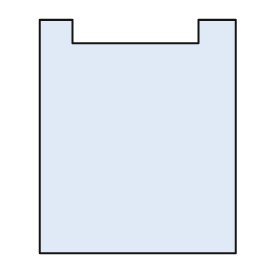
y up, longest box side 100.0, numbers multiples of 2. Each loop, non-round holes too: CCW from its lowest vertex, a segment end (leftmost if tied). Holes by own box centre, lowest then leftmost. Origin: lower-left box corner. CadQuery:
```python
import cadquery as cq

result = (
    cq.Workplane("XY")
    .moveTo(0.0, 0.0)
    .lineTo(84.0, 0.0)
    .lineTo(84.0, 100.0)
    .lineTo(68.0, 100.0)
    .lineTo(68.0, 90.0)
    .lineTo(14.0, 90.0)
    .lineTo(14.0, 100.0)
    .lineTo(0.0, 100.0)
    .close()
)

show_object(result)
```